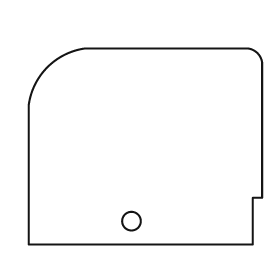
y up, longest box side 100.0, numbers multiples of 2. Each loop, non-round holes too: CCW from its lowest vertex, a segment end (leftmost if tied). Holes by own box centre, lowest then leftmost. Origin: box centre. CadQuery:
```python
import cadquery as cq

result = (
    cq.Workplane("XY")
    .moveTo(-50.0, -42.0)
    .lineTo(46.0, -42.0)
    .lineTo(46.0, -22.0)
    .lineTo(50.0, -22.0)
    .lineTo(50.0, 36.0)
    .threePointArc((48.0, 40.0), (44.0, 42.0))
    .lineTo(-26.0, 42.0)
    .threePointArc((-42.0, 34.0), (-50.0, 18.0))
    .close()
    .moveTo(-6.0, -32.0)
    .circle(4.0)
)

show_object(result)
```